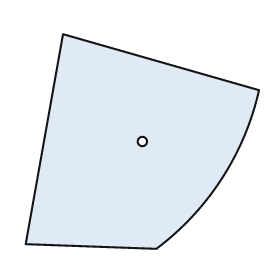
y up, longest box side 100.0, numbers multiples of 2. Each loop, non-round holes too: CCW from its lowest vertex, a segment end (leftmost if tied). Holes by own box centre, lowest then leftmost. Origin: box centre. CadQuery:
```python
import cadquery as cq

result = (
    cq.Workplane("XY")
    .moveTo(6.0, -46.0)
    .threePointArc((34.0, -16.0), (50.0, 22.0))
    .lineTo(-34.0, 46.0)
    .lineTo(-50.0, -44.0)
    .close()
    .moveTo(0.0, 0.0)
    .circle(2.0)
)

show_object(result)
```